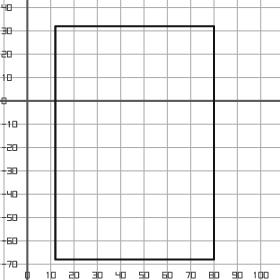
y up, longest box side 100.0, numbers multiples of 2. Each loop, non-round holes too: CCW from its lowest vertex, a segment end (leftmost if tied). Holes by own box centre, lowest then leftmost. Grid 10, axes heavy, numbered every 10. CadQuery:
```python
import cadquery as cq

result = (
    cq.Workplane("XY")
    .moveTo(12.0, -68.0)
    .lineTo(80.0, -68.0)
    .lineTo(80.0, 32.0)
    .lineTo(12.0, 32.0)
    .close()
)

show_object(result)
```